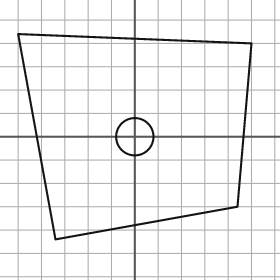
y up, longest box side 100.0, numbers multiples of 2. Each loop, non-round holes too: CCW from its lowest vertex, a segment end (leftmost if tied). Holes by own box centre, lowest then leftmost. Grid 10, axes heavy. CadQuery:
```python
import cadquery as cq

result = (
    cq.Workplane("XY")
    .moveTo(-34.0, -44.0)
    .lineTo(44.0, -30.0)
    .lineTo(50.0, 40.0)
    .lineTo(-50.0, 44.0)
    .close()
    .moveTo(0.0, 0.0)
    .circle(8.0)
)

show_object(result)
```